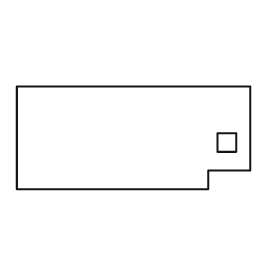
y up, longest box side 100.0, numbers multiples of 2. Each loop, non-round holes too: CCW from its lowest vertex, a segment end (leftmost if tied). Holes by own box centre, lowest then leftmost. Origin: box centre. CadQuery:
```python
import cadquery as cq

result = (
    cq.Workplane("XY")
    .moveTo(-50.0, -22.0)
    .lineTo(32.0, -22.0)
    .lineTo(32.0, -14.0)
    .lineTo(50.0, -14.0)
    .lineTo(50.0, 22.0)
    .lineTo(-50.0, 22.0)
    .close()
    .moveTo(36.0, -6.0)
    .lineTo(44.0, -6.0)
    .lineTo(44.0, 2.0)
    .lineTo(36.0, 2.0)
    .close()
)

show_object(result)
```